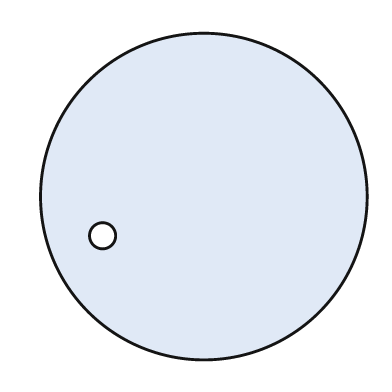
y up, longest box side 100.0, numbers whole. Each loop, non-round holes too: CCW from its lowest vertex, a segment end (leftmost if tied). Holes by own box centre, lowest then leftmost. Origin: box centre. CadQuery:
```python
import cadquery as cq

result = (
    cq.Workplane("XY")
    .moveTo(0.0, 0.0)
    .circle(50.0)
    .moveTo(-31.0, -12.0)
    .circle(4.0)
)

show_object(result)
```